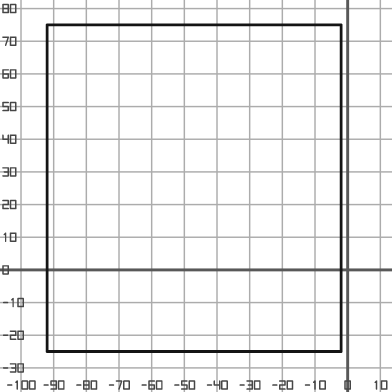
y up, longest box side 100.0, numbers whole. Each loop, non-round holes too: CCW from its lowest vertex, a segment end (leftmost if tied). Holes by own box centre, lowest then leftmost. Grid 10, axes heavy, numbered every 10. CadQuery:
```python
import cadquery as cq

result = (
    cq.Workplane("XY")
    .moveTo(-92.0, -25.0)
    .lineTo(-2.0, -25.0)
    .lineTo(-2.0, 75.0)
    .lineTo(-92.0, 75.0)
    .close()
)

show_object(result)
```